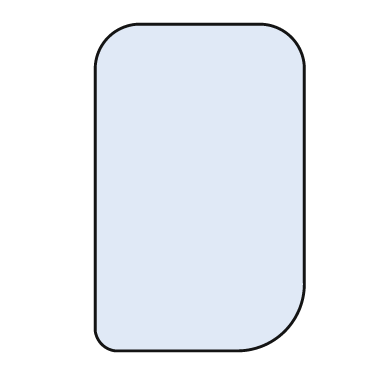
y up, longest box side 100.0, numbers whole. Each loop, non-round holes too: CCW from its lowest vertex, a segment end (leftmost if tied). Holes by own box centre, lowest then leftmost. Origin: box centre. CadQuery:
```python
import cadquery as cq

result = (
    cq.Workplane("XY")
    .moveTo(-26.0, -50.0)
    .lineTo(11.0, -50.0)
    .threePointArc((26.0, -44.0), (32.0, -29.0))
    .lineTo(32.0, 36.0)
    .threePointArc((28.0, 46.0), (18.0, 50.0))
    .lineTo(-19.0, 50.0)
    .threePointArc((-28.0, 46.0), (-32.0, 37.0))
    .lineTo(-32.0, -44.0)
    .threePointArc((-30.0, -48.0), (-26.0, -50.0))
    .close()
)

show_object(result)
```